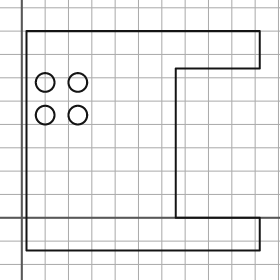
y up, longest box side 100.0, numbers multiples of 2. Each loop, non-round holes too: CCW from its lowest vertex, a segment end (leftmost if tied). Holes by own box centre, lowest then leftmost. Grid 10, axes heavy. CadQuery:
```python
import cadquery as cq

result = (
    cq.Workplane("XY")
    .moveTo(2.0, -14.0)
    .lineTo(102.0, -14.0)
    .lineTo(102.0, 0.0)
    .lineTo(66.0, 0.0)
    .lineTo(66.0, 64.0)
    .lineTo(102.0, 64.0)
    .lineTo(102.0, 80.0)
    .lineTo(2.0, 80.0)
    .close()
    .moveTo(10.0, 44.0)
    .circle(4.0)
    .moveTo(24.0, 44.0)
    .circle(4.0)
    .moveTo(10.0, 58.0)
    .circle(4.0)
    .moveTo(24.0, 58.0)
    .circle(4.0)
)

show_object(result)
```